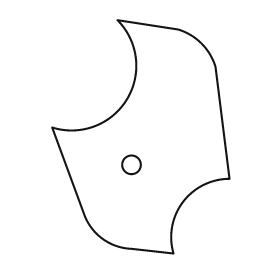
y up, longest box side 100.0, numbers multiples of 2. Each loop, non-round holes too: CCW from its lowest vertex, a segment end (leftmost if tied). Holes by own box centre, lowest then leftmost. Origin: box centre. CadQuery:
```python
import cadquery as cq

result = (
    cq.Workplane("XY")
    .moveTo(14.0, -50.0)
    .threePointArc((18.0, -28.0), (38.0, -18.0))
    .lineTo(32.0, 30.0)
    .threePointArc((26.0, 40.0), (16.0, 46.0))
    .lineTo(-10.0, 50.0)
    .threePointArc((-6.0, 16.0), (-38.0, 4.0))
    .lineTo(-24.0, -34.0)
    .threePointArc((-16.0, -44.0), (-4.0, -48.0))
    .close()
    .moveTo(-4.0, -12.0)
    .circle(4.0)
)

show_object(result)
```